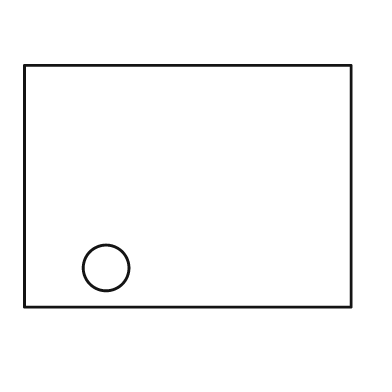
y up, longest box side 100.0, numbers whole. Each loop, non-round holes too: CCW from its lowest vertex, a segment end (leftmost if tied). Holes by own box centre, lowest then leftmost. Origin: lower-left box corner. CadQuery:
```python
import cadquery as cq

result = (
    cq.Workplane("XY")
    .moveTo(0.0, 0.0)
    .lineTo(100.0, 0.0)
    .lineTo(100.0, 74.0)
    .lineTo(0.0, 74.0)
    .close()
    .moveTo(25.0, 12.0)
    .circle(7.0)
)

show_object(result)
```